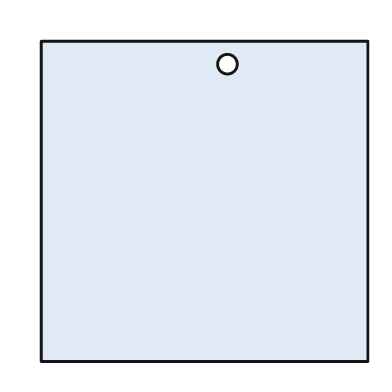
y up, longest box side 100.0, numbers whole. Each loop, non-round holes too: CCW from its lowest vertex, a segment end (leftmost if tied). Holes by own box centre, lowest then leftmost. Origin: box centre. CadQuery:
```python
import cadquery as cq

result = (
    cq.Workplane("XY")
    .moveTo(-50.0, -49.0)
    .lineTo(50.0, -49.0)
    .lineTo(50.0, 49.0)
    .lineTo(-50.0, 49.0)
    .close()
    .moveTo(7.0, 42.0)
    .circle(3.0)
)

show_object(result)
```